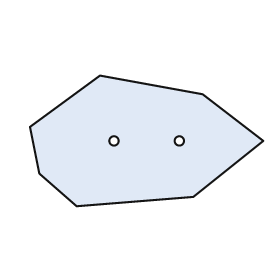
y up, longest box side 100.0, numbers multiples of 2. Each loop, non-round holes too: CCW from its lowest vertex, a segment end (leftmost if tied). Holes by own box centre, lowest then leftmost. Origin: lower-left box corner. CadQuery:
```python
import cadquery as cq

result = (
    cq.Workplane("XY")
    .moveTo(20.0, 0.0)
    .lineTo(70.0, 4.0)
    .lineTo(100.0, 28.0)
    .lineTo(74.0, 48.0)
    .lineTo(30.0, 56.0)
    .lineTo(0.0, 34.0)
    .lineTo(4.0, 14.0)
    .close()
    .moveTo(36.0, 28.0)
    .circle(2.0)
    .moveTo(64.0, 28.0)
    .circle(2.0)
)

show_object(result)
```